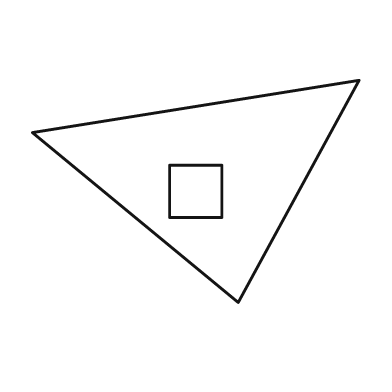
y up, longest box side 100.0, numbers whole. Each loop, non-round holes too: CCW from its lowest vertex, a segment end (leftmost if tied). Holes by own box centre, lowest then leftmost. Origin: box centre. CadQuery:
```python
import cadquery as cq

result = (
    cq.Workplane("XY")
    .moveTo(13.0, -34.0)
    .lineTo(50.0, 34.0)
    .lineTo(-50.0, 18.0)
    .close()
    .moveTo(-8.0, -8.0)
    .lineTo(8.0, -8.0)
    .lineTo(8.0, 8.0)
    .lineTo(-8.0, 8.0)
    .close()
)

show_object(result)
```